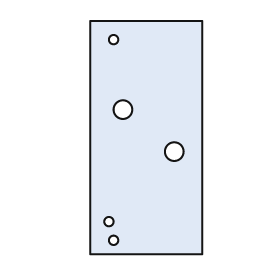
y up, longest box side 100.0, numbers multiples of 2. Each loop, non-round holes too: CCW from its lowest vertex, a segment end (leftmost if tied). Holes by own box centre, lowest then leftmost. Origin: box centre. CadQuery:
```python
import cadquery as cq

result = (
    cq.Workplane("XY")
    .moveTo(-24.0, -50.0)
    .lineTo(24.0, -50.0)
    .lineTo(24.0, 50.0)
    .lineTo(-24.0, 50.0)
    .close()
    .moveTo(-14.0, -44.0)
    .circle(2.0)
    .moveTo(-16.0, -36.0)
    .circle(2.0)
    .moveTo(12.0, -6.0)
    .circle(4.0)
    .moveTo(-10.0, 12.0)
    .circle(4.0)
    .moveTo(-14.0, 42.0)
    .circle(2.0)
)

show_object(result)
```